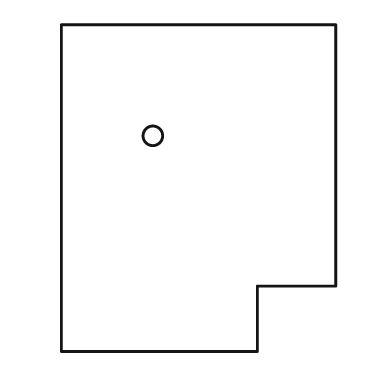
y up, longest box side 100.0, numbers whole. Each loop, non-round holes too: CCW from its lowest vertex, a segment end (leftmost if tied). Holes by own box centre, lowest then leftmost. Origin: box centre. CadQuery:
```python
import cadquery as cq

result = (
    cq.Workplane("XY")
    .moveTo(-42.0, -50.0)
    .lineTo(18.0, -50.0)
    .lineTo(18.0, -30.0)
    .lineTo(42.0, -30.0)
    .lineTo(42.0, 50.0)
    .lineTo(-42.0, 50.0)
    .close()
    .moveTo(-14.0, 16.0)
    .circle(3.0)
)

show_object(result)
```